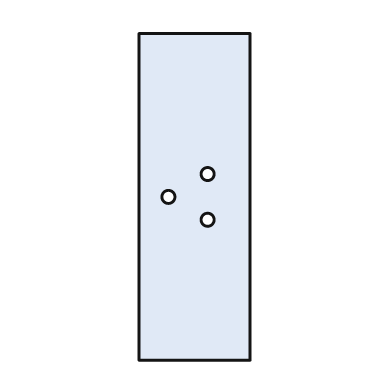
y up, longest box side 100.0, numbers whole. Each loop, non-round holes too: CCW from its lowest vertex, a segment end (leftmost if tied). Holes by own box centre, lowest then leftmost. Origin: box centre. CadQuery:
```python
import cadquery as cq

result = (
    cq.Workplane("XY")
    .moveTo(-17.0, -50.0)
    .lineTo(17.0, -50.0)
    .lineTo(17.0, 50.0)
    .lineTo(-17.0, 50.0)
    .close()
    .moveTo(4.0, -7.0)
    .circle(2.0)
    .moveTo(-8.0, 0.0)
    .circle(2.0)
    .moveTo(4.0, 7.0)
    .circle(2.0)
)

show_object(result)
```